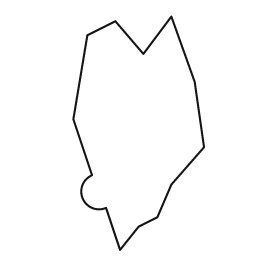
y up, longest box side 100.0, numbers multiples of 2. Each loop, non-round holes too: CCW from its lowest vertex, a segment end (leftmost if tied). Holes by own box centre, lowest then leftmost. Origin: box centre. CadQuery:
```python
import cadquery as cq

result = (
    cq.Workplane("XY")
    .moveTo(-8.0, -50.0)
    .lineTo(0.0, -40.0)
    .lineTo(8.0, -36.0)
    .lineTo(14.0, -22.0)
    .lineTo(28.0, -6.0)
    .lineTo(24.0, 22.0)
    .lineTo(14.0, 50.0)
    .lineTo(2.0, 34.0)
    .lineTo(-10.0, 48.0)
    .lineTo(-22.0, 42.0)
    .lineTo(-28.0, 6.0)
    .lineTo(-20.0, -18.0)
    .threePointArc((-24.0, -28.0), (-14.0, -32.0))
    .close()
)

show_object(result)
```